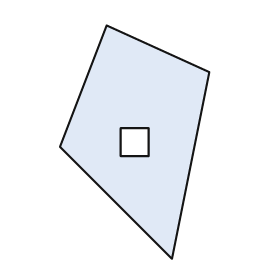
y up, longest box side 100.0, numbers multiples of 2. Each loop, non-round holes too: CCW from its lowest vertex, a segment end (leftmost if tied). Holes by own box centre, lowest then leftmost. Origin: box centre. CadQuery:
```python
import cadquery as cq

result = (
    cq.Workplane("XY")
    .moveTo(16.0, -50.0)
    .lineTo(32.0, 30.0)
    .lineTo(-12.0, 50.0)
    .lineTo(-32.0, -2.0)
    .close()
    .moveTo(-6.0, -6.0)
    .lineTo(6.0, -6.0)
    .lineTo(6.0, 6.0)
    .lineTo(-6.0, 6.0)
    .close()
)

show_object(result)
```